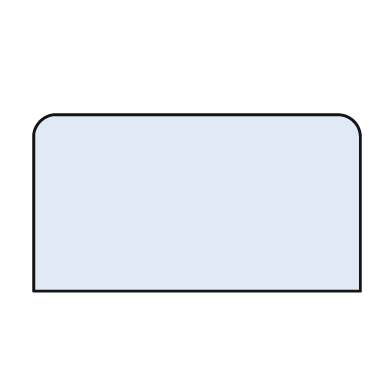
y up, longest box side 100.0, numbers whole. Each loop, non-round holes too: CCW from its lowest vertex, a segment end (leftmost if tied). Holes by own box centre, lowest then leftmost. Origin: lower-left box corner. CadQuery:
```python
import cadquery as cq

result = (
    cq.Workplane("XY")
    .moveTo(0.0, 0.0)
    .lineTo(100.0, 0.0)
    .lineTo(100.0, 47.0)
    .threePointArc((98.0, 52.0), (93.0, 54.0))
    .lineTo(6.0, 54.0)
    .threePointArc((2.0, 52.0), (0.0, 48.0))
    .close()
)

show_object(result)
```